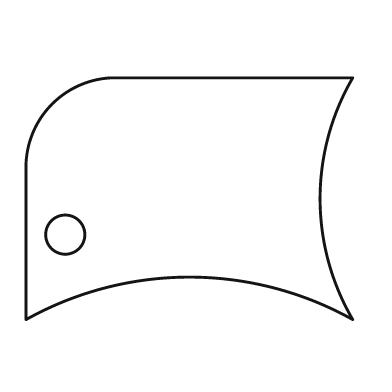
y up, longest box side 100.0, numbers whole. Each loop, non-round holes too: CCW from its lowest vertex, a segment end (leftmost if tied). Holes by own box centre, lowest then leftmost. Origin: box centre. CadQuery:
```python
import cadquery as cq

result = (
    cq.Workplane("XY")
    .moveTo(-50.0, -37.0)
    .threePointArc((0.0, -24.0), (50.0, -37.0))
    .threePointArc((40.0, 0.0), (50.0, 37.0))
    .lineTo(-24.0, 37.0)
    .threePointArc((-42.0, 29.0), (-50.0, 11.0))
    .close()
    .moveTo(-38.0, -11.0)
    .circle(6.0)
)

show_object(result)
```